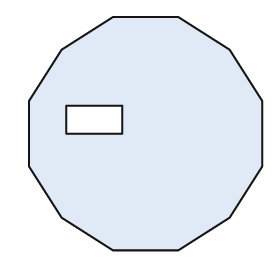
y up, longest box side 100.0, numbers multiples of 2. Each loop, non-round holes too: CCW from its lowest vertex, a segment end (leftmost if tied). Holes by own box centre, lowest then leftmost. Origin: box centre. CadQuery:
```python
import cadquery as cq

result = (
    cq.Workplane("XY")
    .moveTo(-14.0, -50.0)
    .lineTo(14.0, -50.0)
    .lineTo(36.0, -36.0)
    .lineTo(50.0, -14.0)
    .lineTo(50.0, 14.0)
    .lineTo(36.0, 36.0)
    .lineTo(14.0, 50.0)
    .lineTo(-14.0, 50.0)
    .lineTo(-36.0, 36.0)
    .lineTo(-50.0, 14.0)
    .lineTo(-50.0, -14.0)
    .lineTo(-36.0, -36.0)
    .close()
    .moveTo(-34.0, 0.0)
    .lineTo(-10.0, 0.0)
    .lineTo(-10.0, 12.0)
    .lineTo(-34.0, 12.0)
    .close()
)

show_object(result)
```